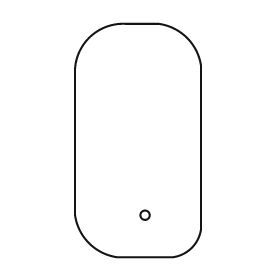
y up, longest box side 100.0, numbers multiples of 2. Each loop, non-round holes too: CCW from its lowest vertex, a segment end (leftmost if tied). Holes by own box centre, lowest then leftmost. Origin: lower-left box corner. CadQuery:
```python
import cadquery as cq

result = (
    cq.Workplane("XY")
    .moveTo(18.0, 0.0)
    .lineTo(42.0, 0.0)
    .threePointArc((50.0, 4.0), (54.0, 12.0))
    .lineTo(54.0, 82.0)
    .threePointArc((48.0, 94.0), (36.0, 100.0))
    .lineTo(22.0, 100.0)
    .threePointArc((6.0, 94.0), (0.0, 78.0))
    .lineTo(0.0, 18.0)
    .threePointArc((6.0, 6.0), (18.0, 0.0))
    .close()
    .moveTo(30.0, 18.0)
    .circle(2.0)
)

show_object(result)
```